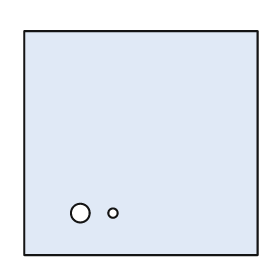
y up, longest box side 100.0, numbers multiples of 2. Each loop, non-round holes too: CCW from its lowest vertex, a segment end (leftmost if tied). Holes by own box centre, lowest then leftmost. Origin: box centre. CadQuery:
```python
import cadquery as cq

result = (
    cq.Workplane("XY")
    .moveTo(-50.0, -48.0)
    .lineTo(50.0, -48.0)
    .lineTo(50.0, 48.0)
    .lineTo(-50.0, 48.0)
    .close()
    .moveTo(-26.0, -30.0)
    .circle(4.0)
    .moveTo(-12.0, -30.0)
    .circle(2.0)
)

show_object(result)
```